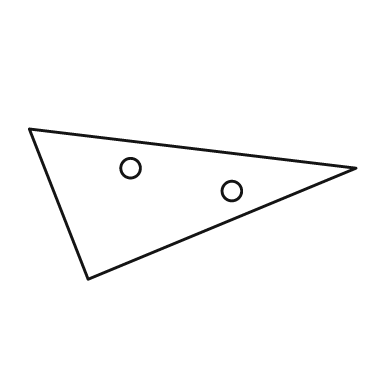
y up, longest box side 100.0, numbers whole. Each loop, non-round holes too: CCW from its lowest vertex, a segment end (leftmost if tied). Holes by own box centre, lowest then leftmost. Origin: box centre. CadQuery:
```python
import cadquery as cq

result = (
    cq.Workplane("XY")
    .moveTo(-32.0, -23.0)
    .lineTo(50.0, 11.0)
    .lineTo(-50.0, 23.0)
    .close()
    .moveTo(12.0, 4.0)
    .circle(3.0)
    .moveTo(-19.0, 11.0)
    .circle(3.0)
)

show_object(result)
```